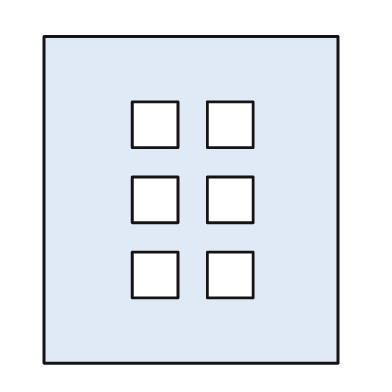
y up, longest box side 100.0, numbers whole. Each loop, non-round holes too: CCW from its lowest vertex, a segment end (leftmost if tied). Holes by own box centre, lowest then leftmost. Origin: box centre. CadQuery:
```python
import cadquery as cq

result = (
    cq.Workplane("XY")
    .moveTo(-45.0, -50.0)
    .lineTo(45.0, -50.0)
    .lineTo(45.0, 50.0)
    .lineTo(-45.0, 50.0)
    .close()
    .moveTo(-18.0, -30.0)
    .lineTo(-4.0, -30.0)
    .lineTo(-4.0, -16.0)
    .lineTo(-18.0, -16.0)
    .close()
    .moveTo(5.0, -30.0)
    .lineTo(19.0, -30.0)
    .lineTo(19.0, -16.0)
    .lineTo(5.0, -16.0)
    .close()
    .moveTo(-18.0, -7.0)
    .lineTo(-4.0, -7.0)
    .lineTo(-4.0, 7.0)
    .lineTo(-18.0, 7.0)
    .close()
    .moveTo(5.0, -7.0)
    .lineTo(19.0, -7.0)
    .lineTo(19.0, 7.0)
    .lineTo(5.0, 7.0)
    .close()
    .moveTo(-18.0, 16.0)
    .lineTo(-4.0, 16.0)
    .lineTo(-4.0, 30.0)
    .lineTo(-18.0, 30.0)
    .close()
    .moveTo(5.0, 16.0)
    .lineTo(19.0, 16.0)
    .lineTo(19.0, 30.0)
    .lineTo(5.0, 30.0)
    .close()
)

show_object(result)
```